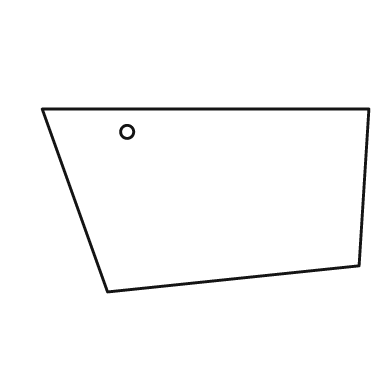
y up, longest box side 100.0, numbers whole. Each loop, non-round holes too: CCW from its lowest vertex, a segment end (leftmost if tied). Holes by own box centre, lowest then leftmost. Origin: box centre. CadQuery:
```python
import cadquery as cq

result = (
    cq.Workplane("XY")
    .moveTo(-30.0, -28.0)
    .lineTo(47.0, -20.0)
    .lineTo(50.0, 28.0)
    .lineTo(-50.0, 28.0)
    .close()
    .moveTo(-24.0, 21.0)
    .circle(2.0)
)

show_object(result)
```